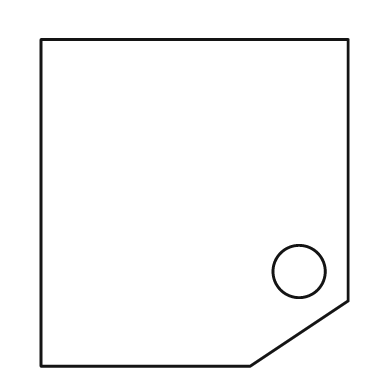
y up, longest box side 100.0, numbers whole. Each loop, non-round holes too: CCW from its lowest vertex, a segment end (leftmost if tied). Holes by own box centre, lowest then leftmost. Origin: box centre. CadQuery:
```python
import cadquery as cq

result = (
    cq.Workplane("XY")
    .moveTo(-47.0, -50.0)
    .lineTo(17.0, -50.0)
    .lineTo(47.0, -30.0)
    .lineTo(47.0, 50.0)
    .lineTo(-47.0, 50.0)
    .close()
    .moveTo(32.0, -21.0)
    .circle(8.0)
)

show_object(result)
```